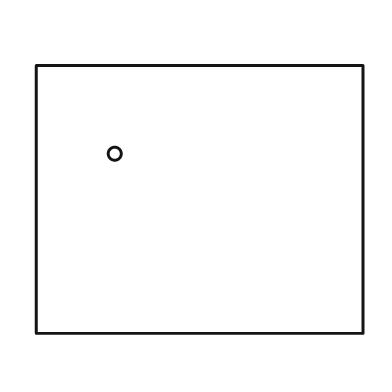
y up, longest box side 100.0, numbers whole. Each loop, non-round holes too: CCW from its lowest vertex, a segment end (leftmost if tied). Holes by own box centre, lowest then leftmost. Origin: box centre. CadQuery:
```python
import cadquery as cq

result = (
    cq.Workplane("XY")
    .moveTo(-50.0, -41.0)
    .lineTo(50.0, -41.0)
    .lineTo(50.0, 41.0)
    .lineTo(-50.0, 41.0)
    .close()
    .moveTo(-26.0, 14.0)
    .circle(2.0)
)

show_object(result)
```